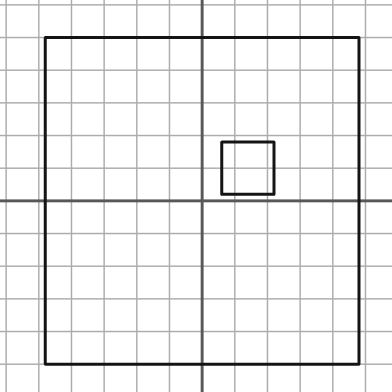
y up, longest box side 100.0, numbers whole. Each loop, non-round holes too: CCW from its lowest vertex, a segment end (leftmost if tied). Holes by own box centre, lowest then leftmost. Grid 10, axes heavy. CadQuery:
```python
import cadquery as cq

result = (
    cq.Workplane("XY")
    .moveTo(-48.0, -50.0)
    .lineTo(48.0, -50.0)
    .lineTo(48.0, 50.0)
    .lineTo(-48.0, 50.0)
    .close()
    .moveTo(6.0, 2.0)
    .lineTo(22.0, 2.0)
    .lineTo(22.0, 18.0)
    .lineTo(6.0, 18.0)
    .close()
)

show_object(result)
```